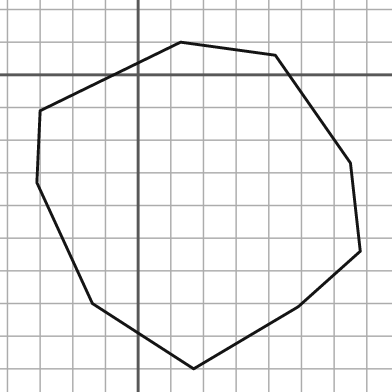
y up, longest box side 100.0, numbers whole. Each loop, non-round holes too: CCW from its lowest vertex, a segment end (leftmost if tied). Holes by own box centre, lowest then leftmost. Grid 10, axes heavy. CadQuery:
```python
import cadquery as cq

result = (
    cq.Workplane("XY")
    .moveTo(17.0, -90.0)
    .lineTo(49.0, -71.0)
    .lineTo(68.0, -54.0)
    .lineTo(65.0, -27.0)
    .lineTo(42.0, 6.0)
    .lineTo(13.0, 10.0)
    .lineTo(-30.0, -11.0)
    .lineTo(-31.0, -33.0)
    .lineTo(-14.0, -70.0)
    .close()
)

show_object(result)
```